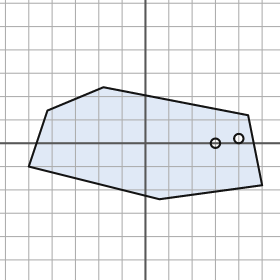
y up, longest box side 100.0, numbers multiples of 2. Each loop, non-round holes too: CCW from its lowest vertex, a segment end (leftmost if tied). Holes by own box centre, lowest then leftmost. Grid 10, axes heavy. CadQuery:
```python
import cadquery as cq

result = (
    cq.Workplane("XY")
    .moveTo(6.0, -24.0)
    .lineTo(50.0, -18.0)
    .lineTo(44.0, 12.0)
    .lineTo(-18.0, 24.0)
    .lineTo(-42.0, 14.0)
    .lineTo(-50.0, -10.0)
    .close()
    .moveTo(30.0, 0.0)
    .circle(2.0)
    .moveTo(40.0, 2.0)
    .circle(2.0)
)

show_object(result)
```